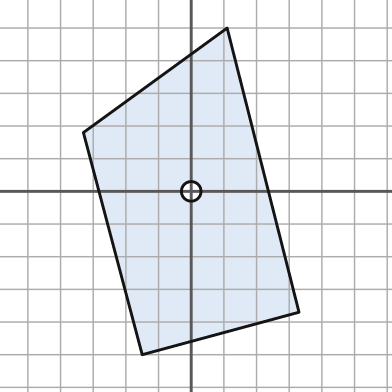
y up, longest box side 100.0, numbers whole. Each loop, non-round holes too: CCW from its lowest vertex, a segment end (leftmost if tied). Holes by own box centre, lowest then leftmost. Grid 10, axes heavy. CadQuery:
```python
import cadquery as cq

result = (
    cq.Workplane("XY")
    .moveTo(-15.0, -50.0)
    .lineTo(33.0, -37.0)
    .lineTo(11.0, 50.0)
    .lineTo(-33.0, 18.0)
    .close()
    .moveTo(0.0, 0.0)
    .circle(3.0)
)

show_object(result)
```